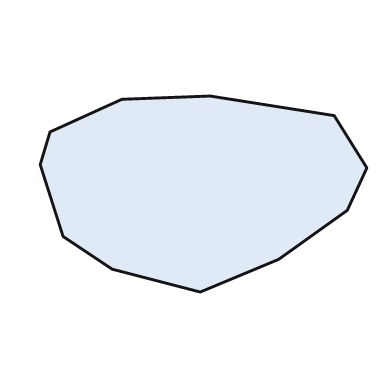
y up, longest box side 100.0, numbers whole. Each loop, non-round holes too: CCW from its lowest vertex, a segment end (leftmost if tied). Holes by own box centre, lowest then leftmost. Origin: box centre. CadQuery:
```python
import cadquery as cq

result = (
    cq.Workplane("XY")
    .moveTo(-1.0, -30.0)
    .lineTo(23.0, -20.0)
    .lineTo(44.0, -5.0)
    .lineTo(50.0, 8.0)
    .lineTo(40.0, 24.0)
    .lineTo(2.0, 30.0)
    .lineTo(-25.0, 29.0)
    .lineTo(-47.0, 19.0)
    .lineTo(-50.0, 9.0)
    .lineTo(-43.0, -13.0)
    .lineTo(-28.0, -23.0)
    .close()
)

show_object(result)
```